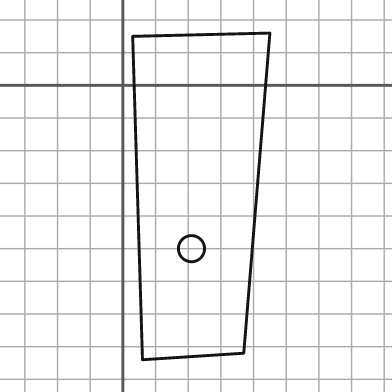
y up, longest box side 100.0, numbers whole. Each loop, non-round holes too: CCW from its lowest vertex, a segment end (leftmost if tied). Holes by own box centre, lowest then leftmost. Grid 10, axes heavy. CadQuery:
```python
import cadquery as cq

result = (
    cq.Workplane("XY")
    .moveTo(6.0, -84.0)
    .lineTo(37.0, -82.0)
    .lineTo(45.0, 16.0)
    .lineTo(3.0, 15.0)
    .close()
    .moveTo(21.0, -50.0)
    .circle(4.0)
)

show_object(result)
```